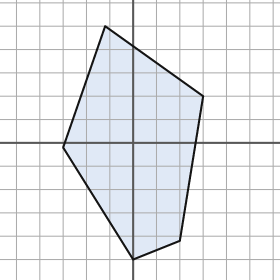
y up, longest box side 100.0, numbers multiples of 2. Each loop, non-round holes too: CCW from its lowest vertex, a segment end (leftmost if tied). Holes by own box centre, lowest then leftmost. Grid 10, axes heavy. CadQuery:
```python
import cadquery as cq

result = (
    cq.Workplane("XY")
    .moveTo(0.0, -50.0)
    .lineTo(20.0, -42.0)
    .lineTo(30.0, 20.0)
    .lineTo(-12.0, 50.0)
    .lineTo(-30.0, -2.0)
    .close()
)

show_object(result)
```